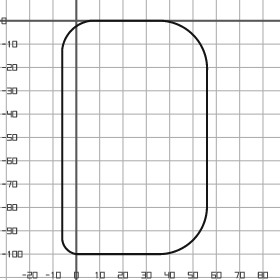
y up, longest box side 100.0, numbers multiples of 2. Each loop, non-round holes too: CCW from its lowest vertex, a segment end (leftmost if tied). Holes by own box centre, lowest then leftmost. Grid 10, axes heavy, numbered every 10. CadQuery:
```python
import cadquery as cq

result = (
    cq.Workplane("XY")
    .moveTo(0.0, -100.0)
    .lineTo(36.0, -100.0)
    .threePointArc((50.0, -94.0), (56.0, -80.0))
    .lineTo(56.0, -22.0)
    .threePointArc((50.0, -6.0), (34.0, 0.0))
    .lineTo(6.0, 0.0)
    .threePointArc((-2.0, -4.0), (-6.0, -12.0))
    .lineTo(-6.0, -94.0)
    .threePointArc((-4.0, -98.0), (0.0, -100.0))
    .close()
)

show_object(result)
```